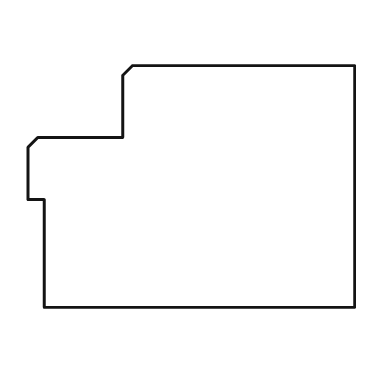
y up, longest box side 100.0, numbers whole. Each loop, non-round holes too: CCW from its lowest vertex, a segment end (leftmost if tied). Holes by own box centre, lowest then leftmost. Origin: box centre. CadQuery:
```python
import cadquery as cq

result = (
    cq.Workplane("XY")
    .moveTo(-45.0, -37.0)
    .lineTo(50.0, -37.0)
    .lineTo(50.0, 37.0)
    .lineTo(-18.0, 37.0)
    .lineTo(-21.0, 34.0)
    .lineTo(-21.0, 15.0)
    .lineTo(-47.0, 15.0)
    .lineTo(-50.0, 12.0)
    .lineTo(-50.0, -4.0)
    .lineTo(-45.0, -4.0)
    .close()
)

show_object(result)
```